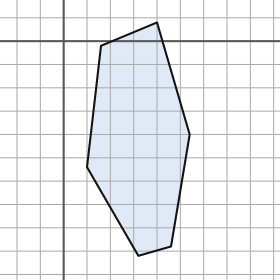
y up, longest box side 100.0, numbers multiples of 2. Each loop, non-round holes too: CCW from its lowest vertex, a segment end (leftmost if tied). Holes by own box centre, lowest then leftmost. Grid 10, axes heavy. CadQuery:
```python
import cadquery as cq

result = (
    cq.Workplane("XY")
    .moveTo(32.0, -92.0)
    .lineTo(46.0, -88.0)
    .lineTo(54.0, -40.0)
    .lineTo(40.0, 8.0)
    .lineTo(16.0, -2.0)
    .lineTo(10.0, -54.0)
    .close()
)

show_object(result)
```